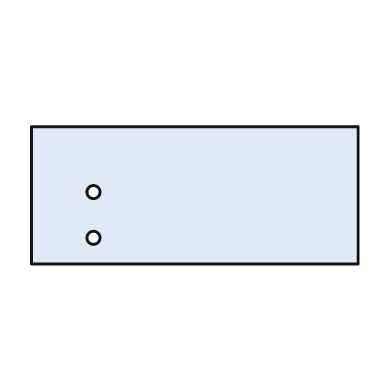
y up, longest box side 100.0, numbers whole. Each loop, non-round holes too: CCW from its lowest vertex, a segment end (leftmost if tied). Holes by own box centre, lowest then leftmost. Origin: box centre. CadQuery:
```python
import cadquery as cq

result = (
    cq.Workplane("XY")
    .moveTo(-50.0, -21.0)
    .lineTo(50.0, -21.0)
    .lineTo(50.0, 21.0)
    .lineTo(-50.0, 21.0)
    .close()
    .moveTo(-31.0, -13.0)
    .circle(2.0)
    .moveTo(-31.0, 1.0)
    .circle(2.0)
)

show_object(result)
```